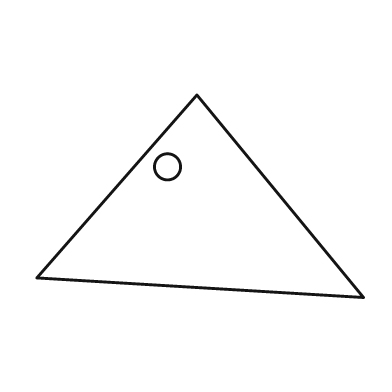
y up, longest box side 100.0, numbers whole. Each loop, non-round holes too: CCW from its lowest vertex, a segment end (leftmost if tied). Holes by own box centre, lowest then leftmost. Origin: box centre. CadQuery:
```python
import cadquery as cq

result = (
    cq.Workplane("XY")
    .moveTo(50.0, -31.0)
    .lineTo(-1.0, 31.0)
    .lineTo(-50.0, -25.0)
    .close()
    .moveTo(-10.0, 9.0)
    .circle(4.0)
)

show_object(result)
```